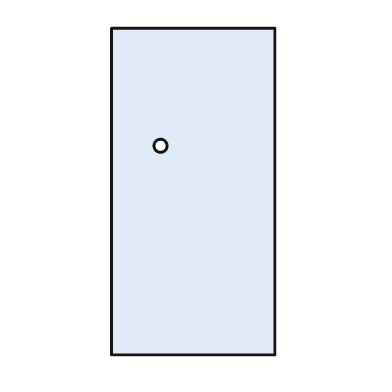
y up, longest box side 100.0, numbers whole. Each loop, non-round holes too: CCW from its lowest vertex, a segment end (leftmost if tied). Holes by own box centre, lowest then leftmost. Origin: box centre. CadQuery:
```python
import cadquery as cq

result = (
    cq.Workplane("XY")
    .moveTo(-25.0, -50.0)
    .lineTo(25.0, -50.0)
    .lineTo(25.0, 50.0)
    .lineTo(-25.0, 50.0)
    .close()
    .moveTo(-10.0, 14.0)
    .circle(2.0)
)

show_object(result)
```